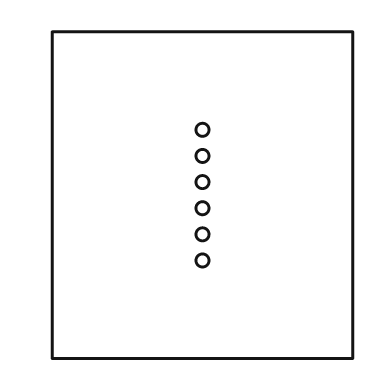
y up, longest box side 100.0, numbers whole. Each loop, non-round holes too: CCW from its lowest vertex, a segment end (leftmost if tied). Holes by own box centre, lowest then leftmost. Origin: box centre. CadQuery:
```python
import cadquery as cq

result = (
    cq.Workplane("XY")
    .moveTo(-46.0, -50.0)
    .lineTo(46.0, -50.0)
    .lineTo(46.0, 50.0)
    .lineTo(-46.0, 50.0)
    .close()
    .moveTo(0.0, -20.0)
    .circle(2.0)
    .moveTo(0.0, -12.0)
    .circle(2.0)
    .moveTo(0.0, -4.0)
    .circle(2.0)
    .moveTo(0.0, 4.0)
    .circle(2.0)
    .moveTo(0.0, 12.0)
    .circle(2.0)
    .moveTo(0.0, 20.0)
    .circle(2.0)
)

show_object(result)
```